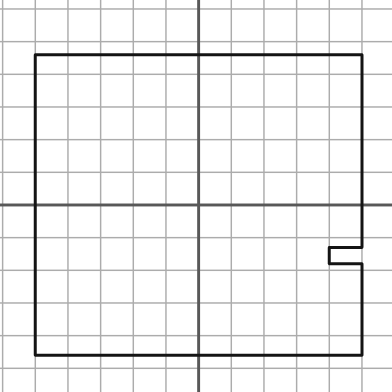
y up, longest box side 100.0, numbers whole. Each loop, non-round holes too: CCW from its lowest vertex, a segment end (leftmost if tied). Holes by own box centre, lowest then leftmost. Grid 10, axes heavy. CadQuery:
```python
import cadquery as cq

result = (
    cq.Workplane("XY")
    .moveTo(-50.0, -46.0)
    .lineTo(50.0, -46.0)
    .lineTo(50.0, -18.0)
    .lineTo(40.0, -18.0)
    .lineTo(40.0, -13.0)
    .lineTo(50.0, -13.0)
    .lineTo(50.0, 46.0)
    .lineTo(-50.0, 46.0)
    .close()
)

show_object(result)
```